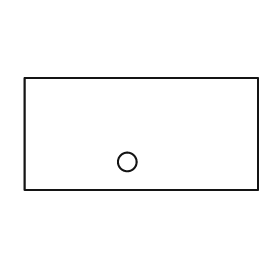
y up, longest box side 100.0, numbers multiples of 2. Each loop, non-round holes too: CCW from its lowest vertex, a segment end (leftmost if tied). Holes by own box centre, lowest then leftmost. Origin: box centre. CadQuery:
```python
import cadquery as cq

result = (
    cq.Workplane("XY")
    .moveTo(-50.0, -24.0)
    .lineTo(50.0, -24.0)
    .lineTo(50.0, 24.0)
    .lineTo(-50.0, 24.0)
    .close()
    .moveTo(-6.0, -12.0)
    .circle(4.0)
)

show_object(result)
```